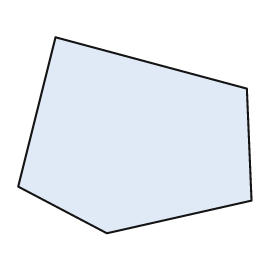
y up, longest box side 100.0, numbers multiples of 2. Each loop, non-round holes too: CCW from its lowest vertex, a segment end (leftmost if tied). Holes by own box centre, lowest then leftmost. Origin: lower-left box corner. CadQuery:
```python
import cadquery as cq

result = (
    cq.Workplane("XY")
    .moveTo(38.0, 0.0)
    .lineTo(100.0, 14.0)
    .lineTo(98.0, 62.0)
    .lineTo(16.0, 84.0)
    .lineTo(0.0, 20.0)
    .close()
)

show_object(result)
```